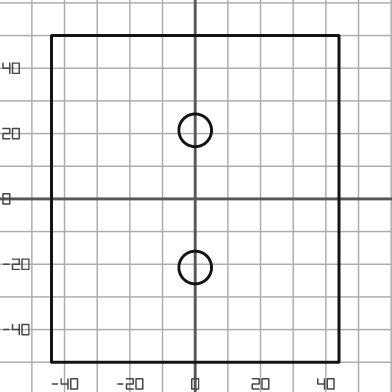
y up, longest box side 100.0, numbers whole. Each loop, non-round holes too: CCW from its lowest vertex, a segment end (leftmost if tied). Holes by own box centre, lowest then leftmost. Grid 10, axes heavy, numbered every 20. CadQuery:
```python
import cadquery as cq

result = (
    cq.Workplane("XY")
    .moveTo(-44.0, -50.0)
    .lineTo(44.0, -50.0)
    .lineTo(44.0, 50.0)
    .lineTo(-44.0, 50.0)
    .close()
    .moveTo(0.0, -21.0)
    .circle(5.0)
    .moveTo(0.0, 21.0)
    .circle(5.0)
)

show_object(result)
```